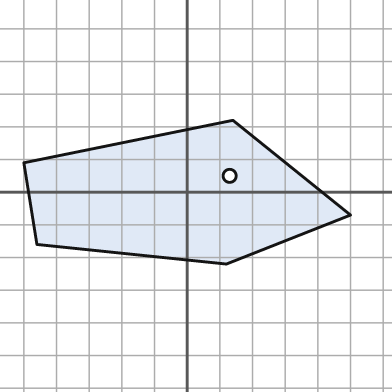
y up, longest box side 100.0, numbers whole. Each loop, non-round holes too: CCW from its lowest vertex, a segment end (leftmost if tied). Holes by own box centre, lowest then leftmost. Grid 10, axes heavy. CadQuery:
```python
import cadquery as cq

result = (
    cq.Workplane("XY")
    .moveTo(12.0, -22.0)
    .lineTo(50.0, -7.0)
    .lineTo(14.0, 22.0)
    .lineTo(-50.0, 9.0)
    .lineTo(-46.0, -16.0)
    .close()
    .moveTo(13.0, 5.0)
    .circle(2.0)
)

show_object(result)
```